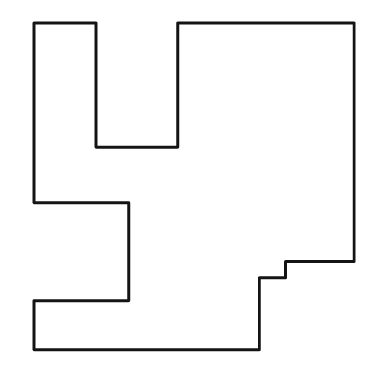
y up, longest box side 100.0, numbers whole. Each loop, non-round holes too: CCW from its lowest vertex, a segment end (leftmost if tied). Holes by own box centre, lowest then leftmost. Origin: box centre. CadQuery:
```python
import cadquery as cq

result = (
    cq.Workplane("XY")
    .moveTo(-49.0, -50.0)
    .lineTo(20.0, -50.0)
    .lineTo(20.0, -28.0)
    .lineTo(28.0, -28.0)
    .lineTo(28.0, -23.0)
    .lineTo(49.0, -23.0)
    .lineTo(49.0, 50.0)
    .lineTo(-5.0, 50.0)
    .lineTo(-5.0, 12.0)
    .lineTo(-30.0, 12.0)
    .lineTo(-30.0, 50.0)
    .lineTo(-49.0, 50.0)
    .lineTo(-49.0, -5.0)
    .lineTo(-20.0, -5.0)
    .lineTo(-20.0, -35.0)
    .lineTo(-49.0, -35.0)
    .close()
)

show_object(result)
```